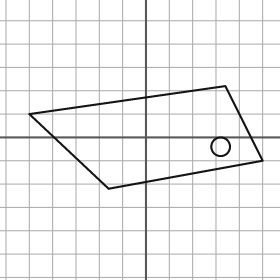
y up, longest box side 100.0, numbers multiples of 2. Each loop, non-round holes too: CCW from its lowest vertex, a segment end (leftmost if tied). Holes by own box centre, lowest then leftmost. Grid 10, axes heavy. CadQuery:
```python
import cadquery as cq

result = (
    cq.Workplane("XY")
    .moveTo(-16.0, -22.0)
    .lineTo(50.0, -10.0)
    .lineTo(34.0, 22.0)
    .lineTo(-50.0, 10.0)
    .close()
    .moveTo(32.0, -4.0)
    .circle(4.0)
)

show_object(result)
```